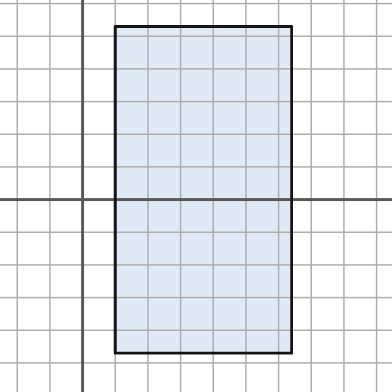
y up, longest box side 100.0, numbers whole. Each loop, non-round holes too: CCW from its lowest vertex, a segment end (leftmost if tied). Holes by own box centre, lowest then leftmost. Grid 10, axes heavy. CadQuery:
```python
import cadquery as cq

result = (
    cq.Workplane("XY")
    .moveTo(10.0, -47.0)
    .lineTo(64.0, -47.0)
    .lineTo(64.0, 53.0)
    .lineTo(10.0, 53.0)
    .close()
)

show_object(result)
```